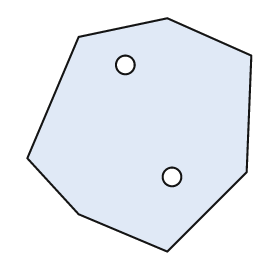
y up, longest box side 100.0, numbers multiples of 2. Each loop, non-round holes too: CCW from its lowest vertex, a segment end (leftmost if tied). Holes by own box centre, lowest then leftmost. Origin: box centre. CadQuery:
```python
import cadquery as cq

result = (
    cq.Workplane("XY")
    .moveTo(12.0, -50.0)
    .lineTo(46.0, -16.0)
    .lineTo(48.0, 34.0)
    .lineTo(12.0, 50.0)
    .lineTo(-26.0, 42.0)
    .lineTo(-48.0, -10.0)
    .lineTo(-26.0, -34.0)
    .close()
    .moveTo(14.0, -18.0)
    .circle(4.0)
    .moveTo(-6.0, 30.0)
    .circle(4.0)
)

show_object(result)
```